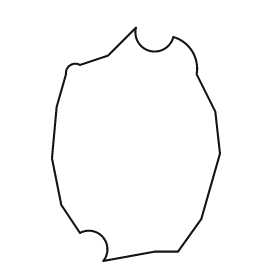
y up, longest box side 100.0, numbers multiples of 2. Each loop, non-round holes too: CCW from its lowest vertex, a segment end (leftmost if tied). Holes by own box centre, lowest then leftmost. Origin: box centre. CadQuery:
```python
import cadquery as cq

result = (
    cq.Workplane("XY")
    .moveTo(-14.0, -50.0)
    .lineTo(8.0, -46.0)
    .lineTo(18.0, -46.0)
    .lineTo(28.0, -32.0)
    .lineTo(36.0, -4.0)
    .lineTo(34.0, 14.0)
    .lineTo(26.0, 30.0)
    .threePointArc((24.0, 40.0), (16.0, 46.0))
    .threePointArc((6.0, 40.0), (0.0, 50.0))
    .lineTo(-12.0, 38.0)
    .lineTo(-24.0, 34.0)
    .threePointArc((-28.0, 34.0), (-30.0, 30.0))
    .lineTo(-34.0, 16.0)
    .lineTo(-36.0, -6.0)
    .lineTo(-32.0, -26.0)
    .lineTo(-24.0, -38.0)
    .threePointArc((-14.0, -40.0), (-14.0, -50.0))
    .close()
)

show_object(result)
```